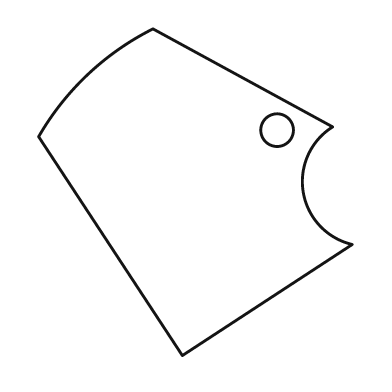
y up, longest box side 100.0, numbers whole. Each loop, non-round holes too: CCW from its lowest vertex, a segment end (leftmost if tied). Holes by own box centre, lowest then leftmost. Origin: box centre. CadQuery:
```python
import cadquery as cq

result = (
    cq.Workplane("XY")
    .moveTo(-4.0, -50.0)
    .lineTo(48.0, -16.0)
    .threePointArc((33.0, 0.0), (42.0, 20.0))
    .lineTo(-13.0, 50.0)
    .threePointArc((-33.0, 36.0), (-48.0, 17.0))
    .close()
    .moveTo(25.0, 19.0)
    .circle(5.0)
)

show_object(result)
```